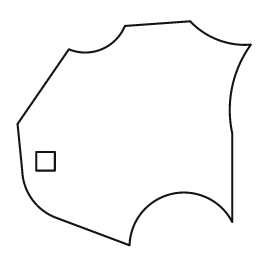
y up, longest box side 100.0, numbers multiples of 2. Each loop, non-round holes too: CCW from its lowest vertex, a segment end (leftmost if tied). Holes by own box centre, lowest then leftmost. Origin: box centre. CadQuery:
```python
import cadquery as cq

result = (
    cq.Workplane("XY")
    .moveTo(-2.0, -48.0)
    .threePointArc((16.0, -26.0), (42.0, -38.0))
    .lineTo(42.0, 0.0)
    .threePointArc((42.0, 20.0), (50.0, 38.0))
    .threePointArc((36.0, 40.0), (24.0, 48.0))
    .lineTo(-4.0, 46.0)
    .threePointArc((-14.0, 36.0), (-28.0, 36.0))
    .lineTo(-50.0, 4.0)
    .lineTo(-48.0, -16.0)
    .threePointArc((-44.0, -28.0), (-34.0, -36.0))
    .close()
    .moveTo(-42.0, -16.0)
    .lineTo(-34.0, -16.0)
    .lineTo(-34.0, -8.0)
    .lineTo(-42.0, -8.0)
    .close()
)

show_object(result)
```